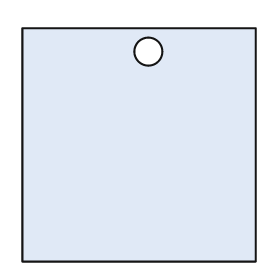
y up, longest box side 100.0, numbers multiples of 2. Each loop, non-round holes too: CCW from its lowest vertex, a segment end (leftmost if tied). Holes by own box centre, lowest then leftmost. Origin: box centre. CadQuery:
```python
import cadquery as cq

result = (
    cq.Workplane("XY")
    .moveTo(-50.0, -50.0)
    .lineTo(50.0, -50.0)
    .lineTo(50.0, 50.0)
    .lineTo(-50.0, 50.0)
    .close()
    .moveTo(4.0, 40.0)
    .circle(6.0)
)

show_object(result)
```